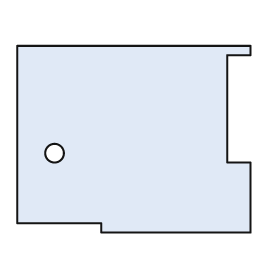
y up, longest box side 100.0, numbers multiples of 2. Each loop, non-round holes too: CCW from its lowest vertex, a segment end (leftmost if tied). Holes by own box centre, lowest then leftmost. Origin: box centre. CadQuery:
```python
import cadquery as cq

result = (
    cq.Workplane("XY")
    .moveTo(-14.0, -40.0)
    .lineTo(50.0, -40.0)
    .lineTo(50.0, -10.0)
    .lineTo(40.0, -10.0)
    .lineTo(40.0, 36.0)
    .lineTo(50.0, 36.0)
    .lineTo(50.0, 40.0)
    .lineTo(-50.0, 40.0)
    .lineTo(-50.0, -36.0)
    .lineTo(-14.0, -36.0)
    .close()
    .moveTo(-34.0, -6.0)
    .circle(4.0)
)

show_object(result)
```